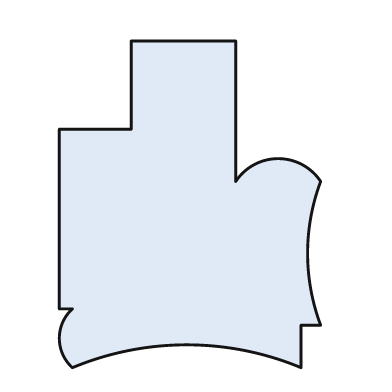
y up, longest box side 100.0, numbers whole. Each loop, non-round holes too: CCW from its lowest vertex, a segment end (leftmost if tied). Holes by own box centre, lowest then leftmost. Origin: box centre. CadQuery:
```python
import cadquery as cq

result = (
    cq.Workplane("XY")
    .moveTo(-36.0, -50.0)
    .threePointArc((-1.0, -43.0), (34.0, -50.0))
    .lineTo(34.0, -37.0)
    .lineTo(40.0, -37.0)
    .threePointArc((36.0, -15.0), (40.0, 7.0))
    .threePointArc((27.0, 14.0), (14.0, 7.0))
    .lineTo(14.0, 50.0)
    .lineTo(-18.0, 50.0)
    .lineTo(-18.0, 23.0)
    .lineTo(-40.0, 23.0)
    .lineTo(-40.0, -32.0)
    .lineTo(-36.0, -32.0)
    .threePointArc((-40.0, -41.0), (-36.0, -50.0))
    .close()
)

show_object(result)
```